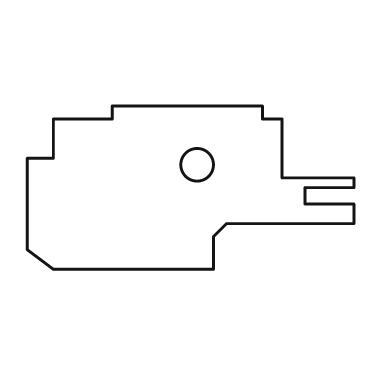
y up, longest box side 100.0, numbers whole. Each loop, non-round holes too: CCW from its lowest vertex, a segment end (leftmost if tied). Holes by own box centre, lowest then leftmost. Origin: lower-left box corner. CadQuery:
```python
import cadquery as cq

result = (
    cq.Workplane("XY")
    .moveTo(8.0, 0.0)
    .lineTo(57.0, 0.0)
    .lineTo(57.0, 10.0)
    .lineTo(61.0, 14.0)
    .lineTo(100.0, 14.0)
    .lineTo(100.0, 20.0)
    .lineTo(85.0, 20.0)
    .lineTo(85.0, 25.0)
    .lineTo(100.0, 25.0)
    .lineTo(100.0, 28.0)
    .lineTo(78.0, 28.0)
    .lineTo(78.0, 46.0)
    .lineTo(72.0, 46.0)
    .lineTo(72.0, 50.0)
    .lineTo(26.0, 50.0)
    .lineTo(26.0, 46.0)
    .lineTo(8.0, 46.0)
    .lineTo(8.0, 34.0)
    .lineTo(0.0, 34.0)
    .lineTo(0.0, 6.0)
    .close()
    .moveTo(52.0, 32.0)
    .circle(5.0)
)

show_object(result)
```